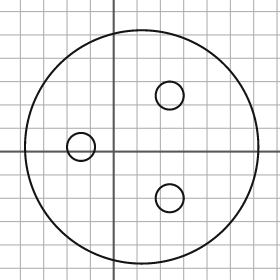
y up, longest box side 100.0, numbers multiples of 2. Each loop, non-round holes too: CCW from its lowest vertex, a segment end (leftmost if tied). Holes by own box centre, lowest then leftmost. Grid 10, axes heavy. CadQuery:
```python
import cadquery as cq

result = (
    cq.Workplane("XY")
    .moveTo(12.0, 2.0)
    .circle(50.0)
    .moveTo(24.0, -20.0)
    .circle(6.0)
    .moveTo(-14.0, 2.0)
    .circle(6.0)
    .moveTo(24.0, 24.0)
    .circle(6.0)
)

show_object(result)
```